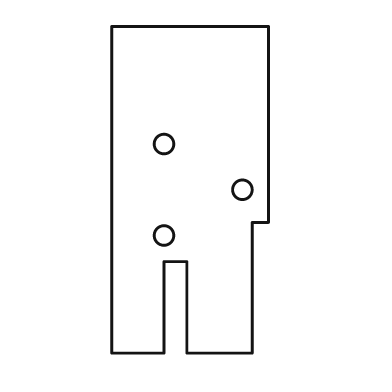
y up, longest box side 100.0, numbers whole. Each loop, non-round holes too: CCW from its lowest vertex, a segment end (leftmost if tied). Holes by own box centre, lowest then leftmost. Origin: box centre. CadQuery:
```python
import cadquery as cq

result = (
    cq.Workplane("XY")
    .moveTo(-24.0, -50.0)
    .lineTo(-8.0, -50.0)
    .lineTo(-8.0, -22.0)
    .lineTo(-1.0, -22.0)
    .lineTo(-1.0, -50.0)
    .lineTo(19.0, -50.0)
    .lineTo(19.0, -10.0)
    .lineTo(24.0, -10.0)
    .lineTo(24.0, 50.0)
    .lineTo(-24.0, 50.0)
    .close()
    .moveTo(-8.0, -14.0)
    .circle(3.0)
    .moveTo(16.0, 0.0)
    .circle(3.0)
    .moveTo(-8.0, 14.0)
    .circle(3.0)
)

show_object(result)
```